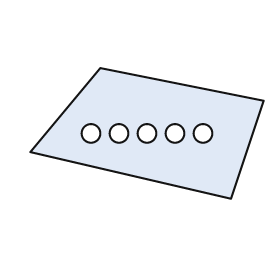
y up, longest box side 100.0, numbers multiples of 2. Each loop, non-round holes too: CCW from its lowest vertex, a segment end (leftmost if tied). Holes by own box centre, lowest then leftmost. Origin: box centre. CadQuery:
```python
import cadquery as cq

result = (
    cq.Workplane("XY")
    .moveTo(36.0, -28.0)
    .lineTo(50.0, 14.0)
    .lineTo(-20.0, 28.0)
    .lineTo(-50.0, -8.0)
    .close()
    .moveTo(-24.0, 0.0)
    .circle(4.0)
    .moveTo(-12.0, 0.0)
    .circle(4.0)
    .moveTo(0.0, 0.0)
    .circle(4.0)
    .moveTo(12.0, 0.0)
    .circle(4.0)
    .moveTo(24.0, 0.0)
    .circle(4.0)
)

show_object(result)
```